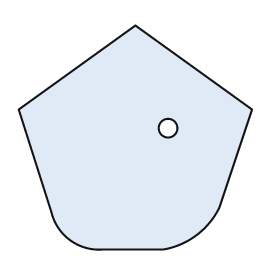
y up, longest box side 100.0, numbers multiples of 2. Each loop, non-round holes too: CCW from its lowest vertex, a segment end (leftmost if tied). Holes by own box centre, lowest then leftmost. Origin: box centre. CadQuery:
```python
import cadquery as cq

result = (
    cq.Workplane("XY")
    .moveTo(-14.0, -48.0)
    .lineTo(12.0, -48.0)
    .threePointArc((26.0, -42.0), (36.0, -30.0))
    .lineTo(50.0, 12.0)
    .lineTo(0.0, 48.0)
    .lineTo(-50.0, 12.0)
    .lineTo(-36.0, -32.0)
    .threePointArc((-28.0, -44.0), (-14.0, -48.0))
    .close()
    .moveTo(14.0, 4.0)
    .circle(4.0)
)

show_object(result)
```